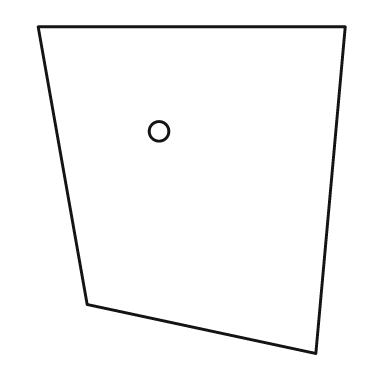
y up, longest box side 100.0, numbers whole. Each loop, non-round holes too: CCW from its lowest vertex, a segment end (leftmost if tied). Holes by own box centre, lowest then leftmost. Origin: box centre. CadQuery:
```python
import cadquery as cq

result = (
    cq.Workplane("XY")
    .moveTo(38.0, -50.0)
    .lineTo(47.0, 50.0)
    .lineTo(-47.0, 50.0)
    .lineTo(-32.0, -35.0)
    .close()
    .moveTo(-10.0, 18.0)
    .circle(3.0)
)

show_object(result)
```